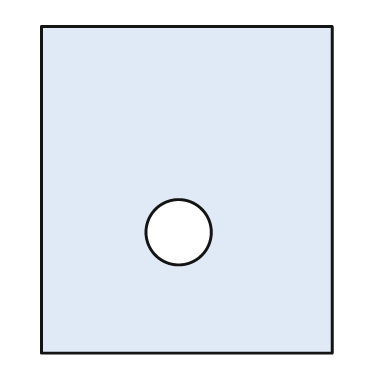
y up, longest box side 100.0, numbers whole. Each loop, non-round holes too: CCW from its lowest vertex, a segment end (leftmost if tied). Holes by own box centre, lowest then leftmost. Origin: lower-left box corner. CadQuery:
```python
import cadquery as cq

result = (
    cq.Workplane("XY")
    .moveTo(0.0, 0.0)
    .lineTo(89.0, 0.0)
    .lineTo(89.0, 100.0)
    .lineTo(0.0, 100.0)
    .close()
    .moveTo(42.0, 37.0)
    .circle(10.0)
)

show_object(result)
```